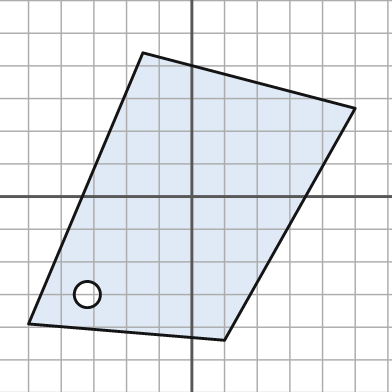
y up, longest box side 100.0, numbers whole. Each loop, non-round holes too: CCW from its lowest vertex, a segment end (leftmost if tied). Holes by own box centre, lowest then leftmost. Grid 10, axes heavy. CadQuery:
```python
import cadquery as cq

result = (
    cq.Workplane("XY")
    .moveTo(10.0, -44.0)
    .lineTo(50.0, 27.0)
    .lineTo(-15.0, 44.0)
    .lineTo(-50.0, -39.0)
    .close()
    .moveTo(-32.0, -30.0)
    .circle(4.0)
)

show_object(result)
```